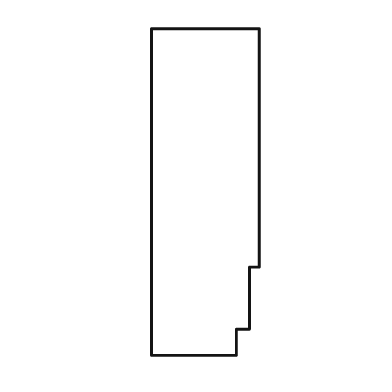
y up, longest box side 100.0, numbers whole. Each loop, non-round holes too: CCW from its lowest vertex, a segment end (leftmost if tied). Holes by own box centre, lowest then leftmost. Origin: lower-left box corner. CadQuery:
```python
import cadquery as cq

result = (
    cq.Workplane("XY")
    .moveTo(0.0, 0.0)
    .lineTo(26.0, 0.0)
    .lineTo(26.0, 8.0)
    .lineTo(30.0, 8.0)
    .lineTo(30.0, 27.0)
    .lineTo(33.0, 27.0)
    .lineTo(33.0, 100.0)
    .lineTo(0.0, 100.0)
    .close()
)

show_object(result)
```